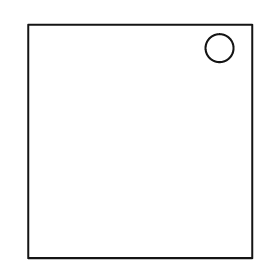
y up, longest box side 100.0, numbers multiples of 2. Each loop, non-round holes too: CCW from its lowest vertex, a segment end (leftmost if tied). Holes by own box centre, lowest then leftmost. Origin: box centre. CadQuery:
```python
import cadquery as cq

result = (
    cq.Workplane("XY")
    .moveTo(-48.0, -50.0)
    .lineTo(48.0, -50.0)
    .lineTo(48.0, 50.0)
    .lineTo(-48.0, 50.0)
    .close()
    .moveTo(34.0, 40.0)
    .circle(6.0)
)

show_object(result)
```